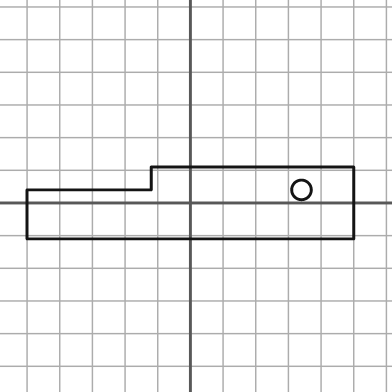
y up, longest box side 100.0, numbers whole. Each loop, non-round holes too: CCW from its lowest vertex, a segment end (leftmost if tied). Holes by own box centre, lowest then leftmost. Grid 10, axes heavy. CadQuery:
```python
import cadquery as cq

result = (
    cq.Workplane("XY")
    .moveTo(-50.0, -11.0)
    .lineTo(50.0, -11.0)
    .lineTo(50.0, 11.0)
    .lineTo(-12.0, 11.0)
    .lineTo(-12.0, 4.0)
    .lineTo(-50.0, 4.0)
    .close()
    .moveTo(34.0, 4.0)
    .circle(3.0)
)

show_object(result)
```